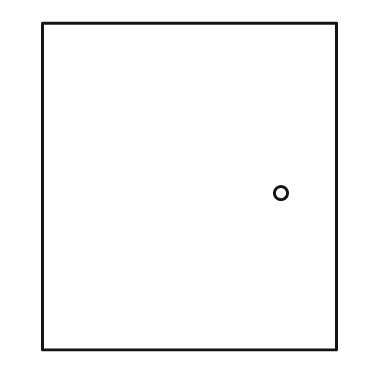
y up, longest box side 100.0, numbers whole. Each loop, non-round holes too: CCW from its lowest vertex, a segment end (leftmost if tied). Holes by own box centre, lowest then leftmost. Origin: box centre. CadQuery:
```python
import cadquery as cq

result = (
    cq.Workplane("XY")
    .moveTo(-45.0, -50.0)
    .lineTo(45.0, -50.0)
    .lineTo(45.0, 50.0)
    .lineTo(-45.0, 50.0)
    .close()
    .moveTo(28.0, -2.0)
    .circle(2.0)
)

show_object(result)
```